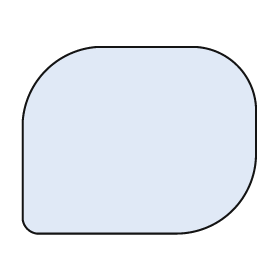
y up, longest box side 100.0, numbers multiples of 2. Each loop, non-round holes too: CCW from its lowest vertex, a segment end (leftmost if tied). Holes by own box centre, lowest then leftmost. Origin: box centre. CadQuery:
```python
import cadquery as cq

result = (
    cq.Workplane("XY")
    .moveTo(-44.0, -40.0)
    .lineTo(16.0, -40.0)
    .threePointArc((40.0, -30.0), (50.0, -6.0))
    .lineTo(50.0, 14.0)
    .threePointArc((42.0, 32.0), (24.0, 40.0))
    .lineTo(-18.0, 40.0)
    .threePointArc((-40.0, 30.0), (-50.0, 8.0))
    .lineTo(-50.0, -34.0)
    .threePointArc((-48.0, -38.0), (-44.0, -40.0))
    .close()
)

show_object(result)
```